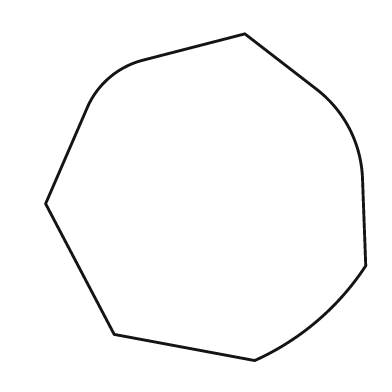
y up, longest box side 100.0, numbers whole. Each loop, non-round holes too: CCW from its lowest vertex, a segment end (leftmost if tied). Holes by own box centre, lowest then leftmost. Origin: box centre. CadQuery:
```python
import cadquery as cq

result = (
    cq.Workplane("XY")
    .moveTo(15.0, -50.0)
    .threePointArc((34.0, -38.0), (49.0, -21.0))
    .lineTo(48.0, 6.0)
    .threePointArc((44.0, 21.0), (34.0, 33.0))
    .lineTo(12.0, 50.0)
    .lineTo(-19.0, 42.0)
    .threePointArc((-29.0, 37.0), (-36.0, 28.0))
    .lineTo(-49.0, -2.0)
    .lineTo(-28.0, -42.0)
    .close()
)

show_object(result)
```